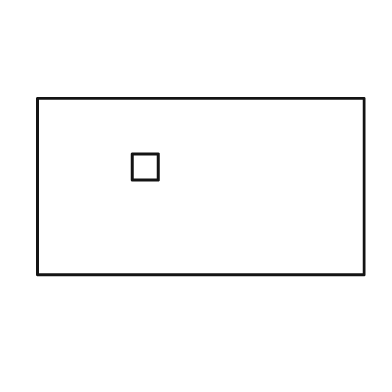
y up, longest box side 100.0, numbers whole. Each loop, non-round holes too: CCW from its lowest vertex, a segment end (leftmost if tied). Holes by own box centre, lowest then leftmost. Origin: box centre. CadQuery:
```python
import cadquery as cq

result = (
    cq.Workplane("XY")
    .moveTo(-50.0, -27.0)
    .lineTo(50.0, -27.0)
    .lineTo(50.0, 27.0)
    .lineTo(-50.0, 27.0)
    .close()
    .moveTo(-21.0, 2.0)
    .lineTo(-13.0, 2.0)
    .lineTo(-13.0, 10.0)
    .lineTo(-21.0, 10.0)
    .close()
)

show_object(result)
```